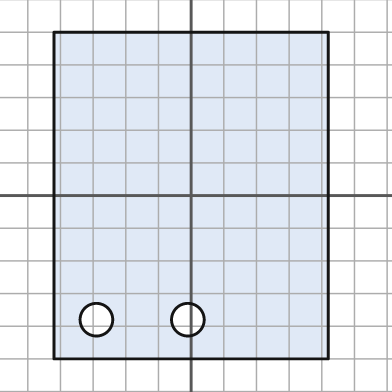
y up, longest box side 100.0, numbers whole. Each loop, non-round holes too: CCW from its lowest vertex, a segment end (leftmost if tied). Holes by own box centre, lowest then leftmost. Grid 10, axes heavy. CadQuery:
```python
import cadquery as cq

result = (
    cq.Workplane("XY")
    .moveTo(-42.0, -50.0)
    .lineTo(42.0, -50.0)
    .lineTo(42.0, 50.0)
    .lineTo(-42.0, 50.0)
    .close()
    .moveTo(-29.0, -38.0)
    .circle(5.0)
    .moveTo(-1.0, -38.0)
    .circle(5.0)
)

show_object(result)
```